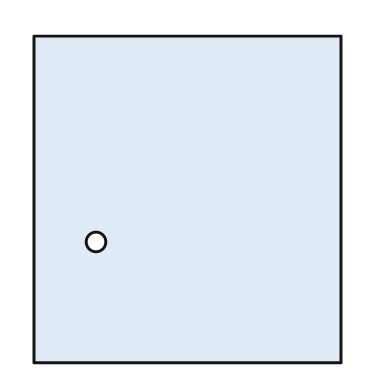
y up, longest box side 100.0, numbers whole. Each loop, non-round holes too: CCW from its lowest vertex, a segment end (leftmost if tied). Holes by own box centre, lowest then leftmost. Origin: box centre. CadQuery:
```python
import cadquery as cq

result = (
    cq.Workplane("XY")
    .moveTo(-47.0, -50.0)
    .lineTo(47.0, -50.0)
    .lineTo(47.0, 50.0)
    .lineTo(-47.0, 50.0)
    .close()
    .moveTo(-28.0, -13.0)
    .circle(3.0)
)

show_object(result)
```